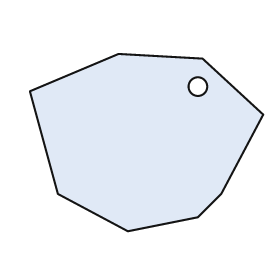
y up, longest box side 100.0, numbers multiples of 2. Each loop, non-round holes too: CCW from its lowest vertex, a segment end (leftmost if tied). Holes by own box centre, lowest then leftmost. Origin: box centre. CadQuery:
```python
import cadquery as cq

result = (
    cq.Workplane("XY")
    .moveTo(-8.0, -38.0)
    .lineTo(22.0, -32.0)
    .lineTo(32.0, -22.0)
    .lineTo(50.0, 12.0)
    .lineTo(24.0, 36.0)
    .lineTo(-12.0, 38.0)
    .lineTo(-50.0, 22.0)
    .lineTo(-38.0, -22.0)
    .close()
    .moveTo(22.0, 24.0)
    .circle(4.0)
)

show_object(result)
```